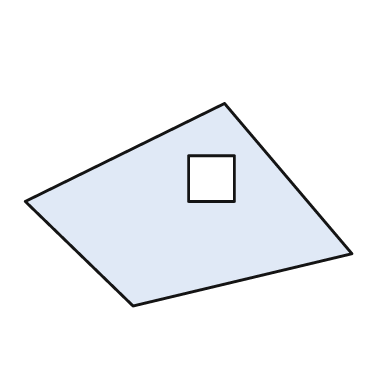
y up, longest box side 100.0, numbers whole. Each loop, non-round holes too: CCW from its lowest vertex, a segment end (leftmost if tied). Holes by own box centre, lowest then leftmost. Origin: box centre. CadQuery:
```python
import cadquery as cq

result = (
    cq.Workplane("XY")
    .moveTo(-17.0, -31.0)
    .lineTo(50.0, -15.0)
    .lineTo(11.0, 31.0)
    .lineTo(-50.0, 1.0)
    .close()
    .moveTo(0.0, 1.0)
    .lineTo(14.0, 1.0)
    .lineTo(14.0, 15.0)
    .lineTo(0.0, 15.0)
    .close()
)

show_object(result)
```